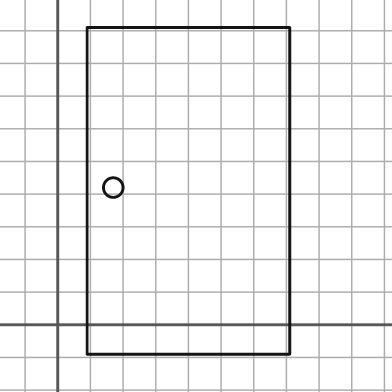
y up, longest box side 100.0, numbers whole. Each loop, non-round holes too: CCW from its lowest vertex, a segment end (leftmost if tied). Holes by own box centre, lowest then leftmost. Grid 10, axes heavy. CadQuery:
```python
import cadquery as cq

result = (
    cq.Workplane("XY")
    .moveTo(9.0, -9.0)
    .lineTo(71.0, -9.0)
    .lineTo(71.0, 91.0)
    .lineTo(9.0, 91.0)
    .close()
    .moveTo(17.0, 42.0)
    .circle(3.0)
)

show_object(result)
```